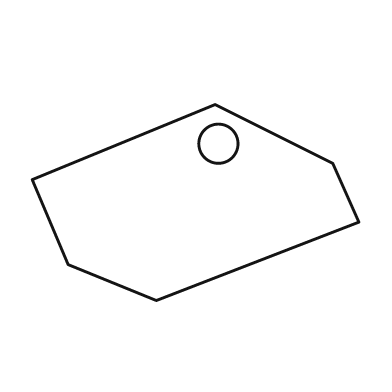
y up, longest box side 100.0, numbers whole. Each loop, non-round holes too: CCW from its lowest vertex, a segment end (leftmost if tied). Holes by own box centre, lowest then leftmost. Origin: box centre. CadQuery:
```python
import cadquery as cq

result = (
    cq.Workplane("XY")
    .moveTo(-12.0, -30.0)
    .lineTo(50.0, -6.0)
    .lineTo(42.0, 12.0)
    .lineTo(6.0, 30.0)
    .lineTo(-50.0, 7.0)
    .lineTo(-39.0, -19.0)
    .close()
    .moveTo(7.0, 18.0)
    .circle(6.0)
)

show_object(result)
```